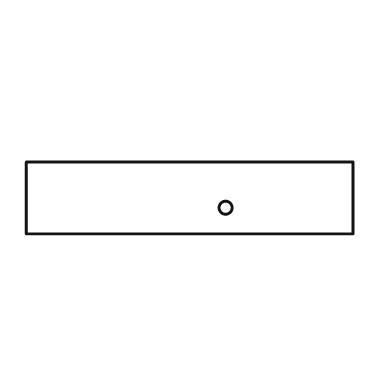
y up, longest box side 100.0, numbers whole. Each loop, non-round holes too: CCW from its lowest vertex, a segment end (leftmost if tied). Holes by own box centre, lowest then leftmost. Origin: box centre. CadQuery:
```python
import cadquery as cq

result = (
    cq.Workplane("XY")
    .moveTo(-50.0, -11.0)
    .lineTo(50.0, -11.0)
    .lineTo(50.0, 11.0)
    .lineTo(-50.0, 11.0)
    .close()
    .moveTo(11.0, -3.0)
    .circle(2.0)
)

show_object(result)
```